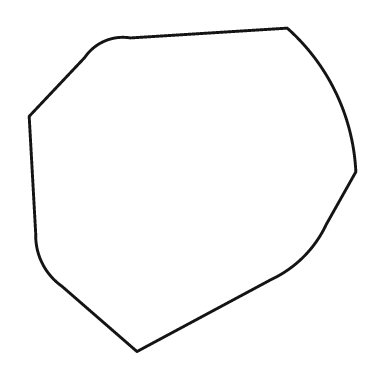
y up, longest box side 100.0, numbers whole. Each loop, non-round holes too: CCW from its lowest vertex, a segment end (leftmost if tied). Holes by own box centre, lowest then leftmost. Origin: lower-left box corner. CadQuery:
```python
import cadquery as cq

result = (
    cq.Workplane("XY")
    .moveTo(33.0, 0.0)
    .lineTo(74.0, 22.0)
    .threePointArc((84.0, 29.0), (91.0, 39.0))
    .lineTo(100.0, 55.0)
    .threePointArc((94.0, 79.0), (79.0, 99.0))
    .lineTo(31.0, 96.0)
    .threePointArc((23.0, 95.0), (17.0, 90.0))
    .lineTo(0.0, 72.0)
    .lineTo(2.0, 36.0)
    .threePointArc((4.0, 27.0), (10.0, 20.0))
    .close()
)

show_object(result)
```